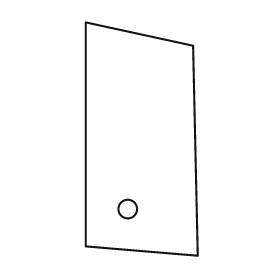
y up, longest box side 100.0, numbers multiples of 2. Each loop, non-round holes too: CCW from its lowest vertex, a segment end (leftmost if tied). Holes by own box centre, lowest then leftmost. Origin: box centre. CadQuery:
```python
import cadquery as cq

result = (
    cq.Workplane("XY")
    .moveTo(24.0, -50.0)
    .lineTo(22.0, 40.0)
    .lineTo(-24.0, 50.0)
    .lineTo(-24.0, -46.0)
    .close()
    .moveTo(-6.0, -30.0)
    .circle(4.0)
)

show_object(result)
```